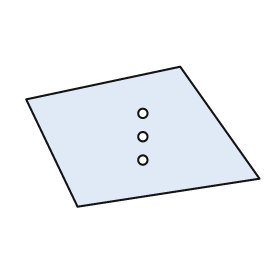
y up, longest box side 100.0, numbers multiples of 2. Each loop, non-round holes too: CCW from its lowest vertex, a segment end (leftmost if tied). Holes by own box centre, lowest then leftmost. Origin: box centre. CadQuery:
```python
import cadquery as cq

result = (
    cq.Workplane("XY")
    .moveTo(-28.0, -30.0)
    .lineTo(50.0, -18.0)
    .lineTo(16.0, 30.0)
    .lineTo(-50.0, 16.0)
    .close()
    .moveTo(0.0, -10.0)
    .circle(2.0)
    .moveTo(0.0, 0.0)
    .circle(2.0)
    .moveTo(0.0, 10.0)
    .circle(2.0)
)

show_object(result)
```